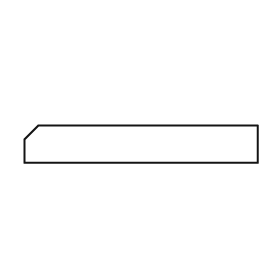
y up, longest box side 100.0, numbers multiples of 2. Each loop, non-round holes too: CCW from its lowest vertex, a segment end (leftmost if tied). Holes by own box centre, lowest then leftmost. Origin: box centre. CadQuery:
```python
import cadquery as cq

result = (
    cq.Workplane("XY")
    .moveTo(-50.0, -8.0)
    .lineTo(50.0, -8.0)
    .lineTo(50.0, 8.0)
    .lineTo(-44.0, 8.0)
    .lineTo(-50.0, 2.0)
    .close()
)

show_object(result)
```